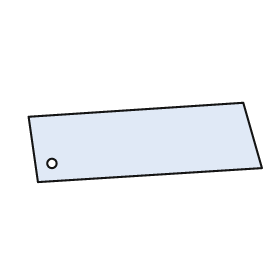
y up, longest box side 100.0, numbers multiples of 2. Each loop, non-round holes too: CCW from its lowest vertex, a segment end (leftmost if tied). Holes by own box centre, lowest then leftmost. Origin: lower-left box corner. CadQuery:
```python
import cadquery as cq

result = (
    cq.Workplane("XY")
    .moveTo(4.0, 0.0)
    .lineTo(100.0, 6.0)
    .lineTo(92.0, 34.0)
    .lineTo(0.0, 28.0)
    .close()
    .moveTo(10.0, 8.0)
    .circle(2.0)
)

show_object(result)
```